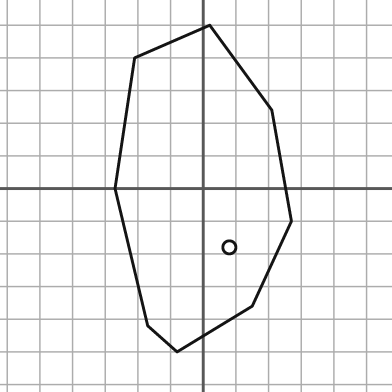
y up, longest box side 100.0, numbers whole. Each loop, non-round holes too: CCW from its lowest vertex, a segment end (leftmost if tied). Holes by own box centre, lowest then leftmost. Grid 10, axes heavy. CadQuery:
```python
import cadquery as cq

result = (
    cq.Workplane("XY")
    .moveTo(-8.0, -50.0)
    .lineTo(15.0, -36.0)
    .lineTo(27.0, -10.0)
    .lineTo(21.0, 24.0)
    .lineTo(2.0, 50.0)
    .lineTo(-21.0, 40.0)
    .lineTo(-27.0, 0.0)
    .lineTo(-17.0, -42.0)
    .close()
    .moveTo(8.0, -18.0)
    .circle(2.0)
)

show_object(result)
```